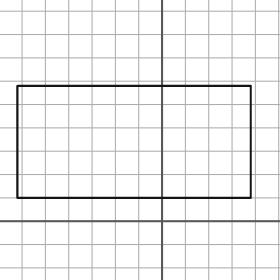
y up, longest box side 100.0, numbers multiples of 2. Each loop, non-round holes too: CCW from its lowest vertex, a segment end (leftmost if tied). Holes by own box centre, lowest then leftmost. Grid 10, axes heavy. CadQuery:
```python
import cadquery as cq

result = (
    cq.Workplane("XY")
    .moveTo(-62.0, 10.0)
    .lineTo(38.0, 10.0)
    .lineTo(38.0, 58.0)
    .lineTo(-62.0, 58.0)
    .close()
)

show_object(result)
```